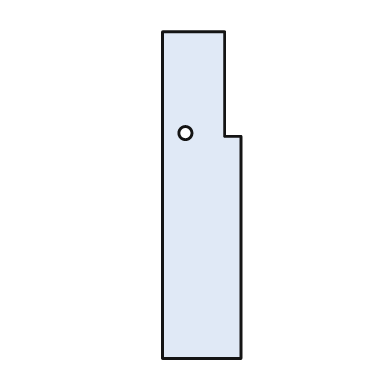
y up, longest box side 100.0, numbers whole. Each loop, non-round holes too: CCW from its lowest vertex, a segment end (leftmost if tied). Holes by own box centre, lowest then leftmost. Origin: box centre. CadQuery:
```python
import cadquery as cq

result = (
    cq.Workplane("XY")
    .moveTo(-12.0, -50.0)
    .lineTo(12.0, -50.0)
    .lineTo(12.0, 18.0)
    .lineTo(7.0, 18.0)
    .lineTo(7.0, 50.0)
    .lineTo(-12.0, 50.0)
    .close()
    .moveTo(-5.0, 19.0)
    .circle(2.0)
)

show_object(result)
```